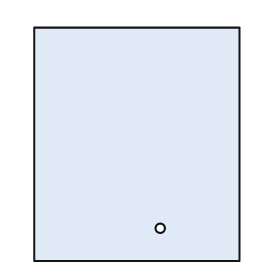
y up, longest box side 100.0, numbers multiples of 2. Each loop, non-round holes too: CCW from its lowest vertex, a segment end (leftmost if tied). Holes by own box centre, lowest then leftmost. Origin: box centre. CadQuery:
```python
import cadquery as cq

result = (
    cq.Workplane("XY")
    .moveTo(-44.0, -50.0)
    .lineTo(44.0, -50.0)
    .lineTo(44.0, 50.0)
    .lineTo(-44.0, 50.0)
    .close()
    .moveTo(10.0, -36.0)
    .circle(2.0)
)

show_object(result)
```